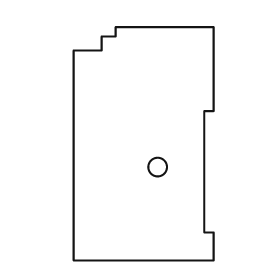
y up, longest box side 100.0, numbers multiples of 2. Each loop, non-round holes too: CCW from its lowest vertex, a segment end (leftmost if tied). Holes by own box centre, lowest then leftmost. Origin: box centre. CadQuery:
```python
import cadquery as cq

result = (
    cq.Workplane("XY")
    .moveTo(-30.0, -50.0)
    .lineTo(30.0, -50.0)
    .lineTo(30.0, -38.0)
    .lineTo(26.0, -38.0)
    .lineTo(26.0, 14.0)
    .lineTo(30.0, 14.0)
    .lineTo(30.0, 50.0)
    .lineTo(-12.0, 50.0)
    .lineTo(-12.0, 46.0)
    .lineTo(-18.0, 46.0)
    .lineTo(-18.0, 40.0)
    .lineTo(-30.0, 40.0)
    .close()
    .moveTo(6.0, -10.0)
    .circle(4.0)
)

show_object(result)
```